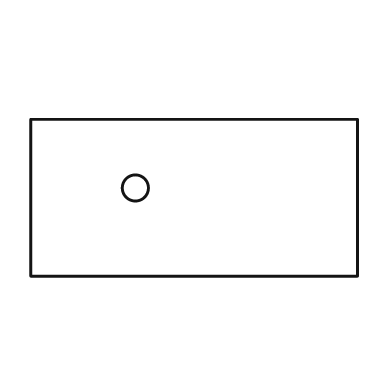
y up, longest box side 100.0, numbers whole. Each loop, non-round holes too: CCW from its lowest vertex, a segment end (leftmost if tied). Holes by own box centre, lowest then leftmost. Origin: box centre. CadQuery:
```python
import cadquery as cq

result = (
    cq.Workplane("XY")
    .moveTo(-50.0, -24.0)
    .lineTo(50.0, -24.0)
    .lineTo(50.0, 24.0)
    .lineTo(-50.0, 24.0)
    .close()
    .moveTo(-18.0, 3.0)
    .circle(4.0)
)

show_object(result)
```